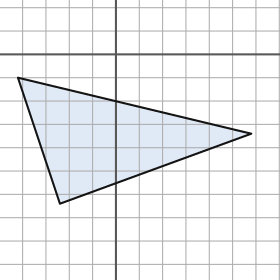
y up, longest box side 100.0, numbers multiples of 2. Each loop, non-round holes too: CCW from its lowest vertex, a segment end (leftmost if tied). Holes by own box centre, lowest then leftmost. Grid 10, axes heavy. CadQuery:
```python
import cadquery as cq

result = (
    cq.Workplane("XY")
    .moveTo(-24.0, -64.0)
    .lineTo(58.0, -34.0)
    .lineTo(-42.0, -10.0)
    .close()
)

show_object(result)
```